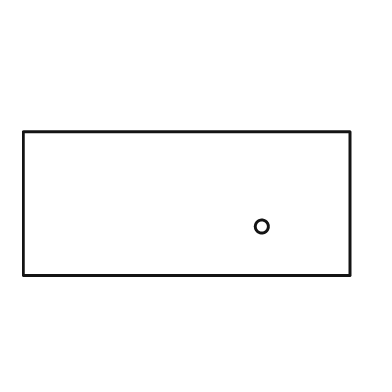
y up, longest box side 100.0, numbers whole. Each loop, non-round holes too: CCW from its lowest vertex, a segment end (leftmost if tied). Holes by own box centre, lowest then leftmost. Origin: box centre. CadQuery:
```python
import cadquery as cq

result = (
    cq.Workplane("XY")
    .moveTo(-50.0, -22.0)
    .lineTo(50.0, -22.0)
    .lineTo(50.0, 22.0)
    .lineTo(-50.0, 22.0)
    .close()
    .moveTo(23.0, -7.0)
    .circle(2.0)
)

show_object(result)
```